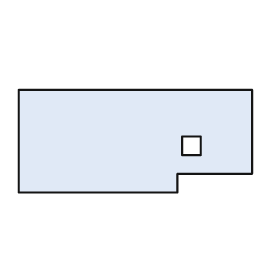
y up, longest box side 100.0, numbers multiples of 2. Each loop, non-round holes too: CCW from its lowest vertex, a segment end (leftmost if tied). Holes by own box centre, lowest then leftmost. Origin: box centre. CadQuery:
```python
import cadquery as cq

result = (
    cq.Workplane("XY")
    .moveTo(-50.0, -22.0)
    .lineTo(18.0, -22.0)
    .lineTo(18.0, -14.0)
    .lineTo(50.0, -14.0)
    .lineTo(50.0, 22.0)
    .lineTo(-50.0, 22.0)
    .close()
    .moveTo(20.0, -6.0)
    .lineTo(28.0, -6.0)
    .lineTo(28.0, 2.0)
    .lineTo(20.0, 2.0)
    .close()
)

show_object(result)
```